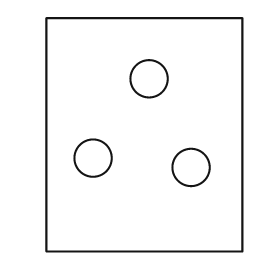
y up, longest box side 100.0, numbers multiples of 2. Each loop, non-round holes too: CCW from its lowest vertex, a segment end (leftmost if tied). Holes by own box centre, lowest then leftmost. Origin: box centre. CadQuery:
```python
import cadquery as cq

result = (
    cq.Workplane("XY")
    .moveTo(-42.0, -50.0)
    .lineTo(42.0, -50.0)
    .lineTo(42.0, 50.0)
    .lineTo(-42.0, 50.0)
    .close()
    .moveTo(20.0, -14.0)
    .circle(8.0)
    .moveTo(-22.0, -10.0)
    .circle(8.0)
    .moveTo(2.0, 24.0)
    .circle(8.0)
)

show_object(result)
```